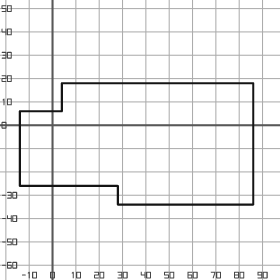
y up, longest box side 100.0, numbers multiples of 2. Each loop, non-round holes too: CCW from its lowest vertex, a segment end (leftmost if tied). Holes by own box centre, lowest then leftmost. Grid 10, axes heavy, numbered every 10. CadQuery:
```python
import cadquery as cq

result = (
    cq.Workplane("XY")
    .moveTo(28.0, -34.0)
    .lineTo(86.0, -34.0)
    .lineTo(86.0, 18.0)
    .lineTo(4.0, 18.0)
    .lineTo(4.0, 6.0)
    .lineTo(-14.0, 6.0)
    .lineTo(-14.0, -26.0)
    .lineTo(28.0, -26.0)
    .close()
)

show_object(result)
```